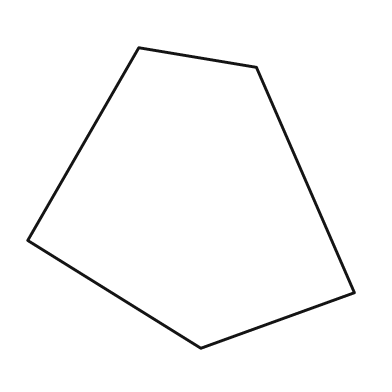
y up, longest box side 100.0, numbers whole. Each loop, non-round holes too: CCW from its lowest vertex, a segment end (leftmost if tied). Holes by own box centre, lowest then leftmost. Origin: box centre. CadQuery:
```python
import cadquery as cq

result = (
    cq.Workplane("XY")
    .moveTo(3.0, -46.0)
    .lineTo(50.0, -29.0)
    .lineTo(20.0, 40.0)
    .lineTo(-16.0, 46.0)
    .lineTo(-50.0, -13.0)
    .close()
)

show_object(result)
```